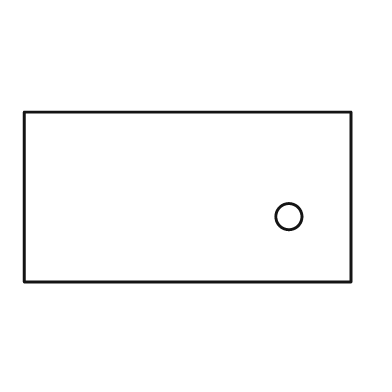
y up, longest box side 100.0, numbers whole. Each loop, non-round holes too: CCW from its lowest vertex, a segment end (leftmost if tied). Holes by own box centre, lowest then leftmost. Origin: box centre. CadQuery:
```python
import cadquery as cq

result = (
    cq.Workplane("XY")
    .moveTo(-50.0, -26.0)
    .lineTo(50.0, -26.0)
    .lineTo(50.0, 26.0)
    .lineTo(-50.0, 26.0)
    .close()
    .moveTo(31.0, -6.0)
    .circle(4.0)
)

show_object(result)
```